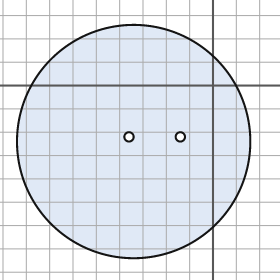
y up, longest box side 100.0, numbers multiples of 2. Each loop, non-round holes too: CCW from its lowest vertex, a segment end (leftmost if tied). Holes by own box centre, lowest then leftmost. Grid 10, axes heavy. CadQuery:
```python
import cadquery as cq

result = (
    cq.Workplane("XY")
    .moveTo(-34.0, -24.0)
    .circle(50.0)
    .moveTo(-36.0, -22.0)
    .circle(2.0)
    .moveTo(-14.0, -22.0)
    .circle(2.0)
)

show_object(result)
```